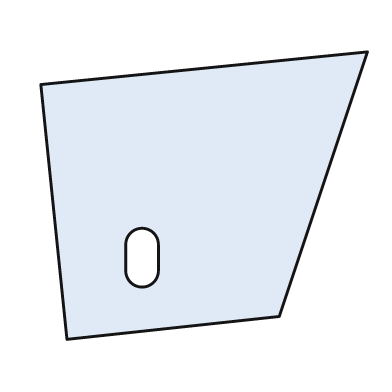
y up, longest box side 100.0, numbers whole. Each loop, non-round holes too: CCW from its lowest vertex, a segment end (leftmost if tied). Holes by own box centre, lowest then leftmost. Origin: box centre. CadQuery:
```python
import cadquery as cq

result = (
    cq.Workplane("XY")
    .moveTo(-42.0, -44.0)
    .lineTo(23.0, -37.0)
    .lineTo(50.0, 44.0)
    .lineTo(-50.0, 34.0)
    .close()
    .moveTo(-24.0, -23.0)
    .threePointArc((-19.0, -28.0), (-14.0, -23.0))
    .lineTo(-14.0, -15.0)
    .threePointArc((-19.0, -10.0), (-24.0, -15.0))
    .close()
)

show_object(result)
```